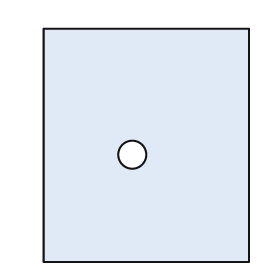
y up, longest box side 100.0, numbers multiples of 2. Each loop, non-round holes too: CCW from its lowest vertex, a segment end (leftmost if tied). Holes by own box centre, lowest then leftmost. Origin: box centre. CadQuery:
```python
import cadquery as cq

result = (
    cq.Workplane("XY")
    .moveTo(-44.0, -50.0)
    .lineTo(44.0, -50.0)
    .lineTo(44.0, 50.0)
    .lineTo(-44.0, 50.0)
    .close()
    .moveTo(-6.0, -4.0)
    .circle(6.0)
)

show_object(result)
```